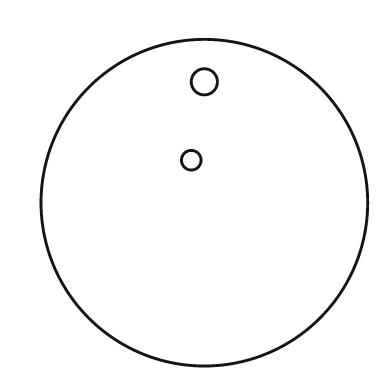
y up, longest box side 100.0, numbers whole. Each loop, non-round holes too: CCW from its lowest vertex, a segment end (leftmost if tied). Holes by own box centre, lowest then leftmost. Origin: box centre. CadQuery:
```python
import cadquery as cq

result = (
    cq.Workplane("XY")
    .moveTo(0.0, 0.0)
    .circle(50.0)
    .moveTo(-4.0, 13.0)
    .circle(3.0)
    .moveTo(0.0, 37.0)
    .circle(4.0)
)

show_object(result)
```